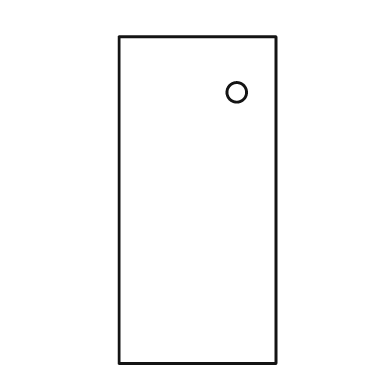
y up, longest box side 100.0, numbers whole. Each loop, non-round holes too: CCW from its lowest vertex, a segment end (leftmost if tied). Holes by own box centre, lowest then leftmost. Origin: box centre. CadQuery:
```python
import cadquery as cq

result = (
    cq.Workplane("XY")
    .moveTo(-24.0, -50.0)
    .lineTo(24.0, -50.0)
    .lineTo(24.0, 50.0)
    .lineTo(-24.0, 50.0)
    .close()
    .moveTo(12.0, 33.0)
    .circle(3.0)
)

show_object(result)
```